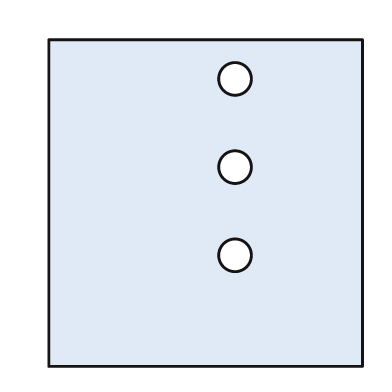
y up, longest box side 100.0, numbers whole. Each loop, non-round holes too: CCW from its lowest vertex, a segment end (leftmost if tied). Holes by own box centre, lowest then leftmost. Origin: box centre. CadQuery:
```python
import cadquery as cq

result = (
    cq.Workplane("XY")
    .moveTo(-48.0, -50.0)
    .lineTo(48.0, -50.0)
    .lineTo(48.0, 50.0)
    .lineTo(-48.0, 50.0)
    .close()
    .moveTo(9.0, -16.0)
    .circle(5.0)
    .moveTo(9.0, 11.0)
    .circle(5.0)
    .moveTo(9.0, 38.0)
    .circle(5.0)
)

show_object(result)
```